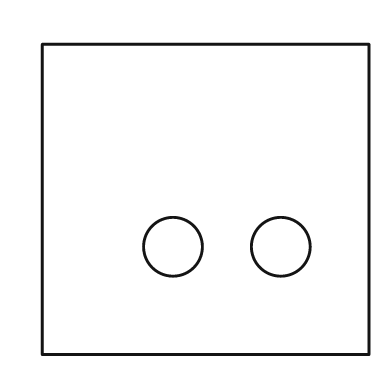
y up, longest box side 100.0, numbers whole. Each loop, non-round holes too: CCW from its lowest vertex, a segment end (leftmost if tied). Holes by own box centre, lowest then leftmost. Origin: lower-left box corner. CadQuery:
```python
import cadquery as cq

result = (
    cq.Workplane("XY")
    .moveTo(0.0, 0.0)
    .lineTo(100.0, 0.0)
    .lineTo(100.0, 95.0)
    .lineTo(0.0, 95.0)
    .close()
    .moveTo(40.0, 33.0)
    .circle(9.0)
    .moveTo(73.0, 33.0)
    .circle(9.0)
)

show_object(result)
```